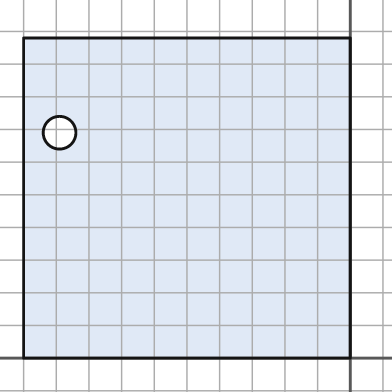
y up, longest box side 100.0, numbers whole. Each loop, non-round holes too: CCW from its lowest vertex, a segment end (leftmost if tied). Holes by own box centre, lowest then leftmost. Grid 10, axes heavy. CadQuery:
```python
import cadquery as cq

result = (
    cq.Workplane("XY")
    .moveTo(-100.0, 0.0)
    .lineTo(0.0, 0.0)
    .lineTo(0.0, 98.0)
    .lineTo(-100.0, 98.0)
    .close()
    .moveTo(-89.0, 69.0)
    .circle(5.0)
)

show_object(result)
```